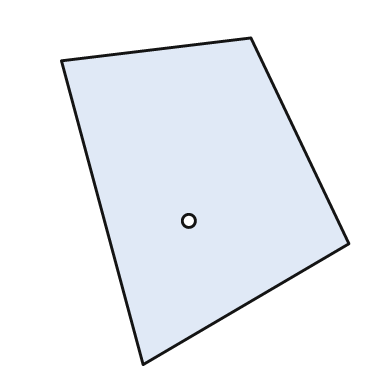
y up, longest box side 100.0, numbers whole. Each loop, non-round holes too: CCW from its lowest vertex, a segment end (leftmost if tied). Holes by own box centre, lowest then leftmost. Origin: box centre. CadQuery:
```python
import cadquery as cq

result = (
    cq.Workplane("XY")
    .moveTo(-19.0, -50.0)
    .lineTo(44.0, -13.0)
    .lineTo(14.0, 50.0)
    .lineTo(-44.0, 43.0)
    .close()
    .moveTo(-5.0, -6.0)
    .circle(2.0)
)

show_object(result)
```